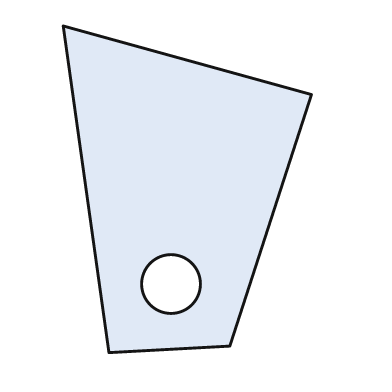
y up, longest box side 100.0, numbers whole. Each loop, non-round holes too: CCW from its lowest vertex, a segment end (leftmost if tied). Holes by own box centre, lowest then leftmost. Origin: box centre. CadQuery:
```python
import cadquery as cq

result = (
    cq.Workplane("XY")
    .moveTo(-24.0, -50.0)
    .lineTo(13.0, -48.0)
    .lineTo(38.0, 29.0)
    .lineTo(-38.0, 50.0)
    .close()
    .moveTo(-5.0, -29.0)
    .circle(9.0)
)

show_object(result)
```